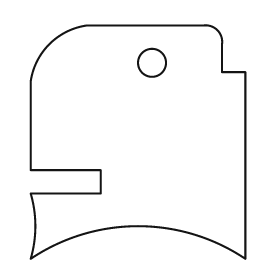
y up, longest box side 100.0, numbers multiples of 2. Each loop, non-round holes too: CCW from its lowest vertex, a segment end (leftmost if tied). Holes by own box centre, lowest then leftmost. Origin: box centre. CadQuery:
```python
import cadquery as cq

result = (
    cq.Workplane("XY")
    .moveTo(-46.0, -50.0)
    .threePointArc((0.0, -36.0), (46.0, -50.0))
    .lineTo(46.0, 30.0)
    .lineTo(36.0, 30.0)
    .lineTo(36.0, 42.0)
    .threePointArc((34.0, 48.0), (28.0, 50.0))
    .lineTo(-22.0, 50.0)
    .threePointArc((-38.0, 42.0), (-46.0, 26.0))
    .lineTo(-46.0, -12.0)
    .lineTo(-16.0, -12.0)
    .lineTo(-16.0, -22.0)
    .lineTo(-46.0, -22.0)
    .threePointArc((-44.0, -36.0), (-46.0, -50.0))
    .close()
    .moveTo(6.0, 34.0)
    .circle(6.0)
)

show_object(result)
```